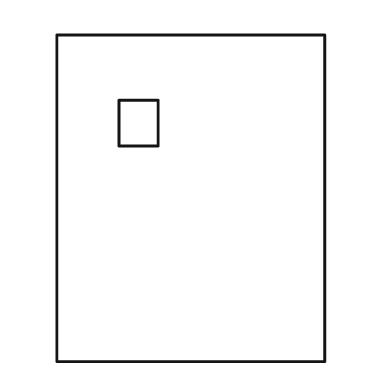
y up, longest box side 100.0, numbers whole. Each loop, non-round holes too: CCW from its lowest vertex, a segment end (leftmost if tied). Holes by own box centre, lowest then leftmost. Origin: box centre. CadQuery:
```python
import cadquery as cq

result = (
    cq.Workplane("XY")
    .moveTo(-41.0, -50.0)
    .lineTo(41.0, -50.0)
    .lineTo(41.0, 50.0)
    .lineTo(-41.0, 50.0)
    .close()
    .moveTo(-22.0, 16.0)
    .lineTo(-10.0, 16.0)
    .lineTo(-10.0, 30.0)
    .lineTo(-22.0, 30.0)
    .close()
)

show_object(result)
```